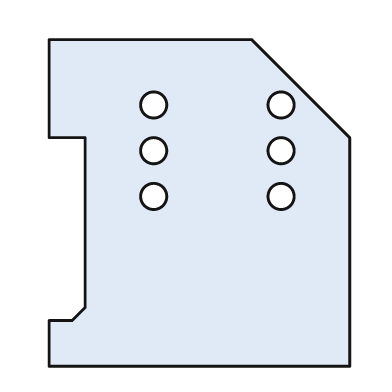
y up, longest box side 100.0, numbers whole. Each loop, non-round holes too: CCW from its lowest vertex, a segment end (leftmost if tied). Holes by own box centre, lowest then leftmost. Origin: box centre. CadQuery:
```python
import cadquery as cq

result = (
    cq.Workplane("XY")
    .moveTo(-46.0, -50.0)
    .lineTo(46.0, -50.0)
    .lineTo(46.0, 20.0)
    .lineTo(16.0, 50.0)
    .lineTo(-46.0, 50.0)
    .lineTo(-46.0, 20.0)
    .lineTo(-35.0, 20.0)
    .lineTo(-35.0, -32.0)
    .lineTo(-39.0, -36.0)
    .lineTo(-46.0, -36.0)
    .close()
    .moveTo(-14.0, 2.0)
    .circle(4.0)
    .moveTo(25.0, 2.0)
    .circle(4.0)
    .moveTo(-14.0, 16.0)
    .circle(4.0)
    .moveTo(25.0, 16.0)
    .circle(4.0)
    .moveTo(-14.0, 30.0)
    .circle(4.0)
    .moveTo(25.0, 30.0)
    .circle(4.0)
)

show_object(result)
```